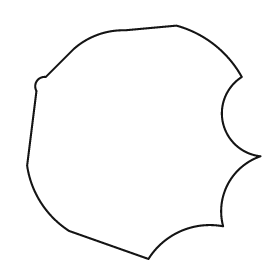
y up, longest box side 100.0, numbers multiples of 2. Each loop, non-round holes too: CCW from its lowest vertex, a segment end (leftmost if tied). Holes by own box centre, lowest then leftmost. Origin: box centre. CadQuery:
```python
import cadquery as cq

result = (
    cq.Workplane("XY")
    .moveTo(2.0, -50.0)
    .threePointArc((16.0, -38.0), (34.0, -36.0))
    .threePointArc((36.0, -18.0), (50.0, -6.0))
    .threePointArc((34.0, 8.0), (42.0, 28.0))
    .threePointArc((30.0, 42.0), (14.0, 50.0))
    .lineTo(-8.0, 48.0)
    .threePointArc((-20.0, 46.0), (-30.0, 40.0))
    .lineTo(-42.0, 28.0)
    .threePointArc((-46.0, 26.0), (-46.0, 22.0))
    .lineTo(-50.0, -10.0)
    .threePointArc((-44.0, -26.0), (-32.0, -38.0))
    .close()
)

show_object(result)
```